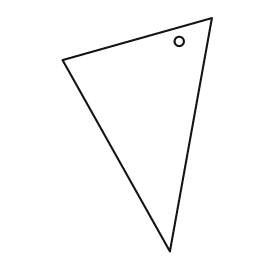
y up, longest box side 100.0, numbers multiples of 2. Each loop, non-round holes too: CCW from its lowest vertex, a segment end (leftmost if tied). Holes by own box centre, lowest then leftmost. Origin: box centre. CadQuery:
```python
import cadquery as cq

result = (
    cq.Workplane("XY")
    .moveTo(14.0, -50.0)
    .lineTo(32.0, 50.0)
    .lineTo(-32.0, 32.0)
    .close()
    .moveTo(18.0, 40.0)
    .circle(2.0)
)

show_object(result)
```